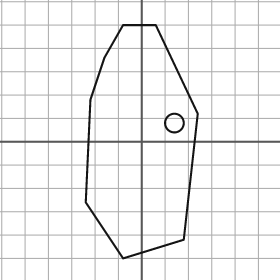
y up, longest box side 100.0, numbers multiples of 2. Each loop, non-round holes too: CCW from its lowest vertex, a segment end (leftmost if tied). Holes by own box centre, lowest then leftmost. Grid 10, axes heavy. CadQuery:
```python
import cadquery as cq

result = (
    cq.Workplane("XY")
    .moveTo(-8.0, -50.0)
    .lineTo(18.0, -42.0)
    .lineTo(24.0, 12.0)
    .lineTo(6.0, 50.0)
    .lineTo(-8.0, 50.0)
    .lineTo(-16.0, 36.0)
    .lineTo(-22.0, 18.0)
    .lineTo(-24.0, -26.0)
    .close()
    .moveTo(14.0, 8.0)
    .circle(4.0)
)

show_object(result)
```